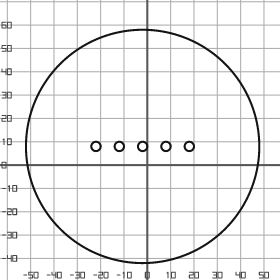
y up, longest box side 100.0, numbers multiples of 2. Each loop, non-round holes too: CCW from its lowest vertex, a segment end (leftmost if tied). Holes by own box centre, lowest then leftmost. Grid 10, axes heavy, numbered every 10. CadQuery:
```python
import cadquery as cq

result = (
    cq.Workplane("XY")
    .moveTo(-2.0, 8.0)
    .circle(50.0)
    .moveTo(-22.0, 8.0)
    .circle(2.0)
    .moveTo(-12.0, 8.0)
    .circle(2.0)
    .moveTo(-2.0, 8.0)
    .circle(2.0)
    .moveTo(8.0, 8.0)
    .circle(2.0)
    .moveTo(18.0, 8.0)
    .circle(2.0)
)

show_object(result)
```